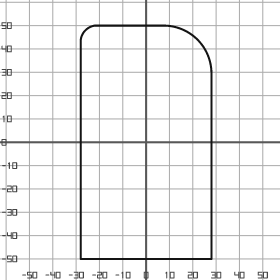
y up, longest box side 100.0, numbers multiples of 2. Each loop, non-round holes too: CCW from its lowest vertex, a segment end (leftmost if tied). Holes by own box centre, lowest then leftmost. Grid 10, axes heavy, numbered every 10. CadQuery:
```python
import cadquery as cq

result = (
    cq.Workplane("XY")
    .moveTo(-28.0, -50.0)
    .lineTo(28.0, -50.0)
    .lineTo(28.0, 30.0)
    .threePointArc((22.0, 44.0), (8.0, 50.0))
    .lineTo(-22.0, 50.0)
    .threePointArc((-26.0, 48.0), (-28.0, 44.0))
    .close()
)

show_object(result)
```